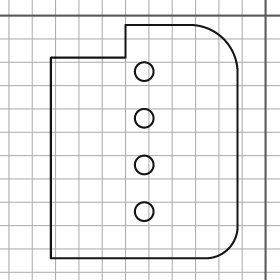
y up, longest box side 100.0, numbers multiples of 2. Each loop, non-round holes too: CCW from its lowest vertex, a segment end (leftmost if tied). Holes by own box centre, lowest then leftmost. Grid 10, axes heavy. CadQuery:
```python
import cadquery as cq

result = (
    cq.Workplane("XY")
    .moveTo(-92.0, -104.0)
    .lineTo(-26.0, -104.0)
    .threePointArc((-16.0, -100.0), (-12.0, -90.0))
    .lineTo(-12.0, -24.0)
    .threePointArc((-18.0, -10.0), (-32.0, -4.0))
    .lineTo(-60.0, -4.0)
    .lineTo(-60.0, -18.0)
    .lineTo(-92.0, -18.0)
    .close()
    .moveTo(-52.0, -84.0)
    .circle(4.0)
    .moveTo(-52.0, -64.0)
    .circle(4.0)
    .moveTo(-52.0, -44.0)
    .circle(4.0)
    .moveTo(-52.0, -24.0)
    .circle(4.0)
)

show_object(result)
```